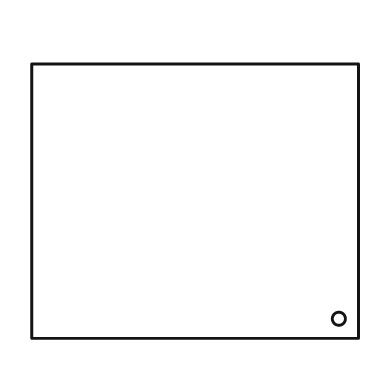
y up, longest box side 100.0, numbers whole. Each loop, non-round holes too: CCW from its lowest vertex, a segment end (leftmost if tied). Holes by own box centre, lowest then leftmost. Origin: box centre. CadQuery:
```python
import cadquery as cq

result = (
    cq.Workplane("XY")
    .moveTo(-50.0, -42.0)
    .lineTo(50.0, -42.0)
    .lineTo(50.0, 42.0)
    .lineTo(-50.0, 42.0)
    .close()
    .moveTo(44.0, -36.0)
    .circle(2.0)
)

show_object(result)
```